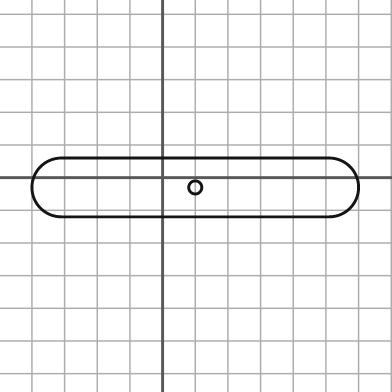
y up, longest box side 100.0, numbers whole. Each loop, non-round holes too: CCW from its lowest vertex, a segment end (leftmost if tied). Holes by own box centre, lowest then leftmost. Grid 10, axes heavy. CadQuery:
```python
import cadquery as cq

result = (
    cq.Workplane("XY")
    .moveTo(-31.0, -12.0)
    .lineTo(51.0, -12.0)
    .threePointArc((60.0, -3.0), (51.0, 6.0))
    .lineTo(-31.0, 6.0)
    .threePointArc((-40.0, -3.0), (-31.0, -12.0))
    .close()
    .moveTo(10.0, -3.0)
    .circle(2.0)
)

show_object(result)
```